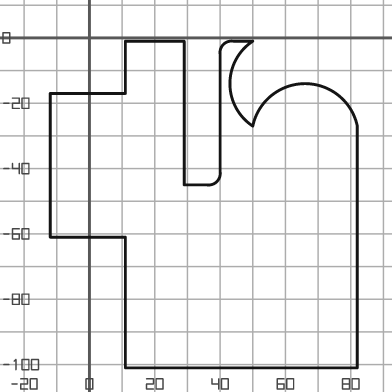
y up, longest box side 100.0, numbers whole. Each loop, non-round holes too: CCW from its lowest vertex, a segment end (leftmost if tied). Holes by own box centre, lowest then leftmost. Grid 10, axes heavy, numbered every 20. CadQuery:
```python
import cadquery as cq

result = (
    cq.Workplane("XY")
    .moveTo(11.0, -101.0)
    .lineTo(82.0, -101.0)
    .lineTo(82.0, -27.0)
    .threePointArc((66.0, -14.0), (50.0, -27.0))
    .threePointArc((43.0, -14.0), (50.0, -1.0))
    .lineTo(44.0, -1.0)
    .threePointArc((41.0, -2.0), (40.0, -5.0))
    .lineTo(40.0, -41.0)
    .threePointArc((39.0, -44.0), (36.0, -45.0))
    .lineTo(29.0, -45.0)
    .lineTo(29.0, -1.0)
    .lineTo(11.0, -1.0)
    .lineTo(11.0, -17.0)
    .lineTo(-12.0, -17.0)
    .lineTo(-12.0, -61.0)
    .lineTo(11.0, -61.0)
    .close()
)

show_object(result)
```